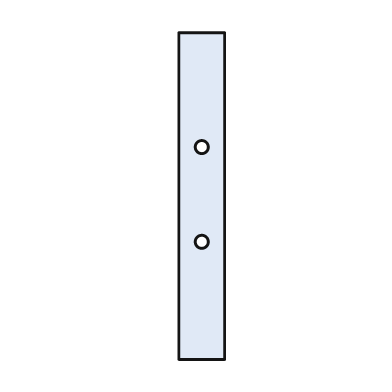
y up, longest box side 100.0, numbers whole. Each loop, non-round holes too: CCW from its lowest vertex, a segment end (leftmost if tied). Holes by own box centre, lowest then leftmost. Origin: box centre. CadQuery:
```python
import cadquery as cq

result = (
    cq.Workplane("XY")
    .moveTo(-7.0, -50.0)
    .lineTo(7.0, -50.0)
    .lineTo(7.0, 50.0)
    .lineTo(-7.0, 50.0)
    .close()
    .moveTo(0.0, -14.0)
    .circle(2.0)
    .moveTo(0.0, 15.0)
    .circle(2.0)
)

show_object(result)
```